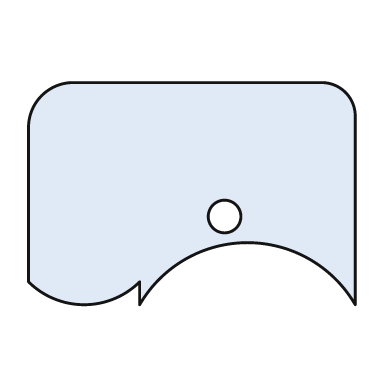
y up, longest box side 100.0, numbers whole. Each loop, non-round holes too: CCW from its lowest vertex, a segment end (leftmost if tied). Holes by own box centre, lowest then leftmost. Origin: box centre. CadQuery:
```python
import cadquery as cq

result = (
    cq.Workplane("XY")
    .moveTo(-16.0, -34.0)
    .threePointArc((17.0, -15.0), (50.0, -34.0))
    .lineTo(50.0, 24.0)
    .threePointArc((47.0, 31.0), (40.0, 34.0))
    .lineTo(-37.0, 34.0)
    .threePointArc((-46.0, 30.0), (-50.0, 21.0))
    .lineTo(-50.0, -27.0)
    .threePointArc((-33.0, -34.0), (-16.0, -27.0))
    .close()
    .moveTo(10.0, -7.0)
    .circle(5.0)
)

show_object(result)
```